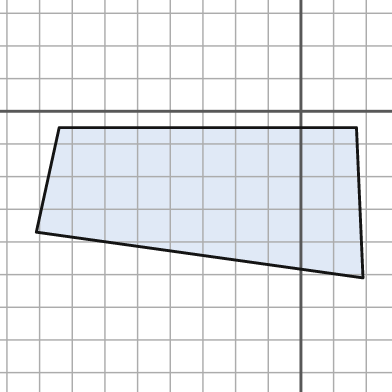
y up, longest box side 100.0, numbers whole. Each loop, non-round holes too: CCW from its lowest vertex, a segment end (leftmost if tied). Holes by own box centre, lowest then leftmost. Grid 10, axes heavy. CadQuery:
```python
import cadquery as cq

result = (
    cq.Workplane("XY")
    .moveTo(19.0, -51.0)
    .lineTo(17.0, -5.0)
    .lineTo(-74.0, -5.0)
    .lineTo(-81.0, -37.0)
    .close()
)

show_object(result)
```